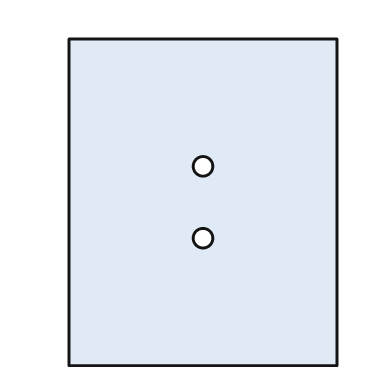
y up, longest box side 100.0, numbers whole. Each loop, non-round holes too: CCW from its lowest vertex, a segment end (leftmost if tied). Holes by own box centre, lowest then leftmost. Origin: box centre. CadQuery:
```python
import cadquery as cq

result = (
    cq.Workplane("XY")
    .moveTo(-41.0, -50.0)
    .lineTo(41.0, -50.0)
    .lineTo(41.0, 50.0)
    .lineTo(-41.0, 50.0)
    .close()
    .moveTo(0.0, -11.0)
    .circle(3.0)
    .moveTo(0.0, 11.0)
    .circle(3.0)
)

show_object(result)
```